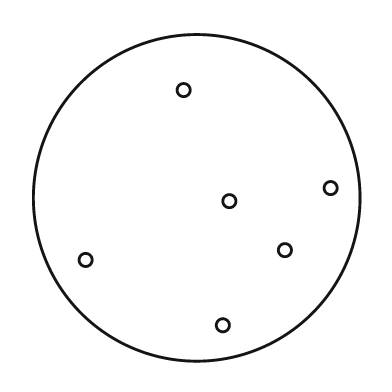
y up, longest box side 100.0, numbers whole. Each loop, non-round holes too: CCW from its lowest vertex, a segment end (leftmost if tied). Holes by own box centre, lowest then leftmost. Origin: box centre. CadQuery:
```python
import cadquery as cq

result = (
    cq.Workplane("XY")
    .moveTo(0.0, 0.0)
    .circle(50.0)
    .moveTo(8.0, -39.0)
    .circle(2.0)
    .moveTo(-34.0, -19.0)
    .circle(2.0)
    .moveTo(27.0, -16.0)
    .circle(2.0)
    .moveTo(10.0, -1.0)
    .circle(2.0)
    .moveTo(41.0, 3.0)
    .circle(2.0)
    .moveTo(-4.0, 33.0)
    .circle(2.0)
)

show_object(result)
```